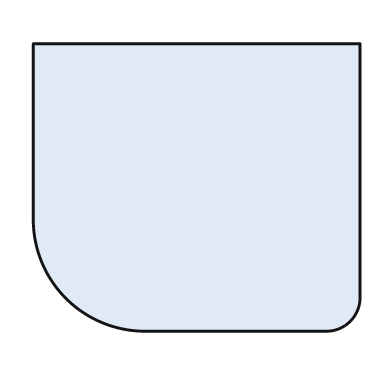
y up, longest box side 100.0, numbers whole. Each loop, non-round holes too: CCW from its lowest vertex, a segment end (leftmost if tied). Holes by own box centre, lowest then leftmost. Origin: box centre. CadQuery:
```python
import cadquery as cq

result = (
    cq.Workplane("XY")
    .moveTo(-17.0, -44.0)
    .lineTo(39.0, -44.0)
    .threePointArc((47.0, -41.0), (50.0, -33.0))
    .lineTo(50.0, 44.0)
    .lineTo(-50.0, 44.0)
    .lineTo(-50.0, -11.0)
    .threePointArc((-40.0, -34.0), (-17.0, -44.0))
    .close()
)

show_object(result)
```